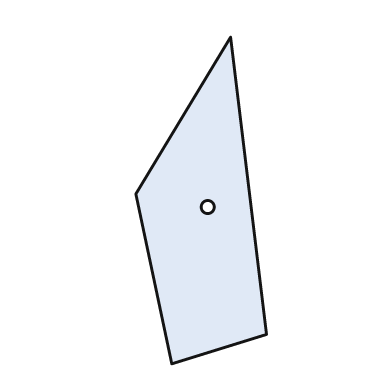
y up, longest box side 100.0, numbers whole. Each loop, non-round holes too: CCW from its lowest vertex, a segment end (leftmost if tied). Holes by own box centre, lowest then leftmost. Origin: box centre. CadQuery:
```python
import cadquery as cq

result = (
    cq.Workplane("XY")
    .moveTo(-9.0, -50.0)
    .lineTo(20.0, -41.0)
    .lineTo(9.0, 50.0)
    .lineTo(-20.0, 2.0)
    .close()
    .moveTo(2.0, -2.0)
    .circle(2.0)
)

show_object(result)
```